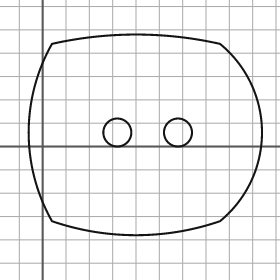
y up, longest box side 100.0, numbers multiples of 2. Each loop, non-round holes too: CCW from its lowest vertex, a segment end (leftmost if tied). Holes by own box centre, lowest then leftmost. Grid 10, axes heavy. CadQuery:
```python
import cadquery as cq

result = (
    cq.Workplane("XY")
    .moveTo(4.0, -32.0)
    .threePointArc((40.0, -38.0), (76.0, -32.0))
    .threePointArc((94.0, 6.0), (76.0, 44.0))
    .threePointArc((40.0, 48.0), (4.0, 44.0))
    .threePointArc((-6.0, 6.0), (4.0, -32.0))
    .close()
    .moveTo(32.0, 6.0)
    .circle(6.0)
    .moveTo(58.0, 6.0)
    .circle(6.0)
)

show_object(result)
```